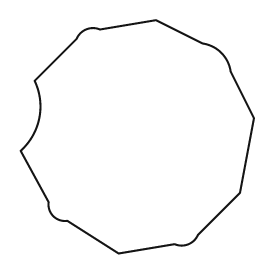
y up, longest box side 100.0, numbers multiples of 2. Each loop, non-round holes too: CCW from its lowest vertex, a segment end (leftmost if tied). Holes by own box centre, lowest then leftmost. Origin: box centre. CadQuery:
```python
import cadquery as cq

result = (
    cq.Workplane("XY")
    .moveTo(-8.0, -50.0)
    .lineTo(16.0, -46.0)
    .threePointArc((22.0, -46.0), (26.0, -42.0))
    .lineTo(44.0, -24.0)
    .lineTo(50.0, 8.0)
    .lineTo(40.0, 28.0)
    .threePointArc((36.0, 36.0), (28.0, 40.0))
    .lineTo(8.0, 50.0)
    .lineTo(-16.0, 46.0)
    .threePointArc((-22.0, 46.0), (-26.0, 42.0))
    .lineTo(-44.0, 24.0)
    .threePointArc((-42.0, 8.0), (-50.0, -6.0))
    .lineTo(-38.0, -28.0)
    .threePointArc((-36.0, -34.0), (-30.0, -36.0))
    .close()
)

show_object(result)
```